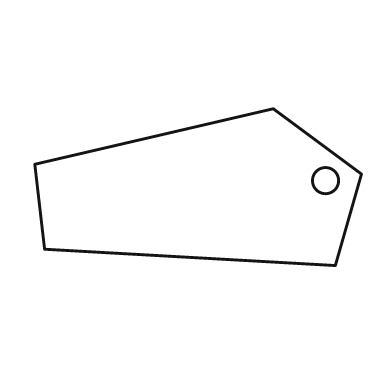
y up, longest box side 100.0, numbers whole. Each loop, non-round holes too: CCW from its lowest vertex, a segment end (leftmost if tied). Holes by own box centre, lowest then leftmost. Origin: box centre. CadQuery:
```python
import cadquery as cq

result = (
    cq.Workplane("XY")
    .moveTo(42.0, -24.0)
    .lineTo(50.0, 4.0)
    .lineTo(23.0, 24.0)
    .lineTo(-50.0, 7.0)
    .lineTo(-47.0, -19.0)
    .close()
    .moveTo(39.0, 2.0)
    .circle(4.0)
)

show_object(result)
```